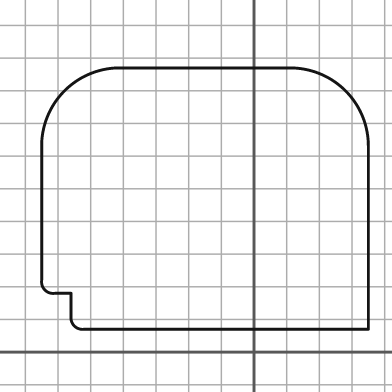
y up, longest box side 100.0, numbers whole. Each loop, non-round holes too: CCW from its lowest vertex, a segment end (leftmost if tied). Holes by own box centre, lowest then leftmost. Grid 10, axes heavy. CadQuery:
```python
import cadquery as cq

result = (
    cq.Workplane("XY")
    .moveTo(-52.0, 7.0)
    .lineTo(35.0, 7.0)
    .lineTo(35.0, 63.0)
    .threePointArc((28.0, 80.0), (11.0, 87.0))
    .lineTo(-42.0, 87.0)
    .threePointArc((-58.0, 80.0), (-65.0, 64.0))
    .lineTo(-65.0, 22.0)
    .threePointArc((-64.0, 19.0), (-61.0, 18.0))
    .lineTo(-56.0, 18.0)
    .lineTo(-56.0, 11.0)
    .threePointArc((-55.0, 8.0), (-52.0, 7.0))
    .close()
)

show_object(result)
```